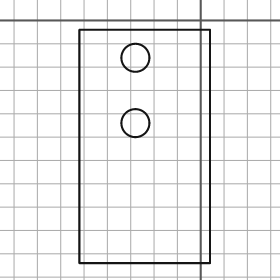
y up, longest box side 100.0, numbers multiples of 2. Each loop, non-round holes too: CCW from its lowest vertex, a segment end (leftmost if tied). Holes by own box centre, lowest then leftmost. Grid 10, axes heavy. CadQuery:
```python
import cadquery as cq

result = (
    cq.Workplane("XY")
    .moveTo(-52.0, -104.0)
    .lineTo(4.0, -104.0)
    .lineTo(4.0, -4.0)
    .lineTo(-52.0, -4.0)
    .close()
    .moveTo(-28.0, -44.0)
    .circle(6.0)
    .moveTo(-28.0, -16.0)
    .circle(6.0)
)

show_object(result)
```